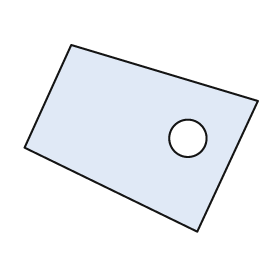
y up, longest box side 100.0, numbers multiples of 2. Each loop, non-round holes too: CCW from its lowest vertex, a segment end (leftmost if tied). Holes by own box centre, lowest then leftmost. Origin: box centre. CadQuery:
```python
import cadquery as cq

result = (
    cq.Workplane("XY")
    .moveTo(24.0, -40.0)
    .lineTo(50.0, 16.0)
    .lineTo(-30.0, 40.0)
    .lineTo(-50.0, -4.0)
    .close()
    .moveTo(20.0, 0.0)
    .circle(8.0)
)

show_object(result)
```